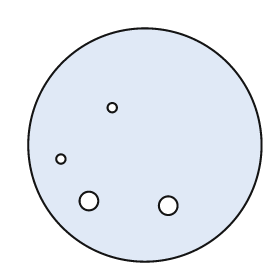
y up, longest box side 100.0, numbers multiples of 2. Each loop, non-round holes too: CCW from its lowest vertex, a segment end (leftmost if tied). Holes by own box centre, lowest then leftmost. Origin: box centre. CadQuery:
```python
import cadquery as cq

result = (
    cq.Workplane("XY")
    .moveTo(0.0, 0.0)
    .circle(50.0)
    .moveTo(10.0, -26.0)
    .circle(4.0)
    .moveTo(-24.0, -24.0)
    .circle(4.0)
    .moveTo(-36.0, -6.0)
    .circle(2.0)
    .moveTo(-14.0, 16.0)
    .circle(2.0)
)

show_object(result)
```